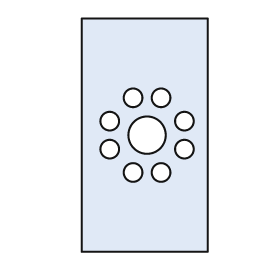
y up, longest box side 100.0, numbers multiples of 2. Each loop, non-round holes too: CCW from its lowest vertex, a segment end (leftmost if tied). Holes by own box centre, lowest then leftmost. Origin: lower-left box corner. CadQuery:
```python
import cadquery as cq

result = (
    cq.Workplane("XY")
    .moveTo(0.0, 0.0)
    .lineTo(54.0, 0.0)
    .lineTo(54.0, 100.0)
    .lineTo(0.0, 100.0)
    .close()
    .moveTo(22.0, 34.0)
    .circle(4.0)
    .moveTo(34.0, 34.0)
    .circle(4.0)
    .moveTo(12.0, 44.0)
    .circle(4.0)
    .moveTo(44.0, 44.0)
    .circle(4.0)
    .moveTo(28.0, 50.0)
    .circle(8.0)
    .moveTo(12.0, 56.0)
    .circle(4.0)
    .moveTo(44.0, 56.0)
    .circle(4.0)
    .moveTo(22.0, 66.0)
    .circle(4.0)
    .moveTo(34.0, 66.0)
    .circle(4.0)
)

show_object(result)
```